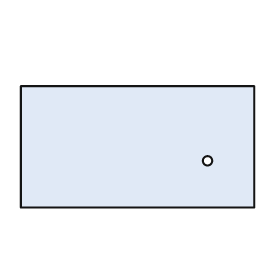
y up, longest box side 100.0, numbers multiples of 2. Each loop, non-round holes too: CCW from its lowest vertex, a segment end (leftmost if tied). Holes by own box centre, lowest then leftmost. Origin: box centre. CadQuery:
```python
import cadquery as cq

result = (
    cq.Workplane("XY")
    .moveTo(-50.0, -26.0)
    .lineTo(50.0, -26.0)
    .lineTo(50.0, 26.0)
    .lineTo(-50.0, 26.0)
    .close()
    .moveTo(30.0, -6.0)
    .circle(2.0)
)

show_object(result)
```